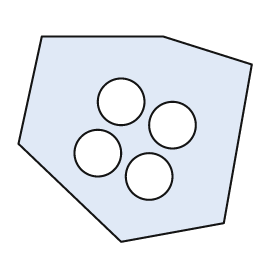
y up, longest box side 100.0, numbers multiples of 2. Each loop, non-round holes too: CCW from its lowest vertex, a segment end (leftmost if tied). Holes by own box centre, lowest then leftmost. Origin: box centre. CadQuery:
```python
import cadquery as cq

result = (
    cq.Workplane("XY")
    .moveTo(-6.0, -44.0)
    .lineTo(38.0, -36.0)
    .lineTo(50.0, 32.0)
    .lineTo(12.0, 44.0)
    .lineTo(-40.0, 44.0)
    .lineTo(-50.0, -2.0)
    .close()
    .moveTo(6.0, -16.0)
    .circle(10.0)
    .moveTo(-16.0, -6.0)
    .circle(10.0)
    .moveTo(16.0, 6.0)
    .circle(10.0)
    .moveTo(-6.0, 16.0)
    .circle(10.0)
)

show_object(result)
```